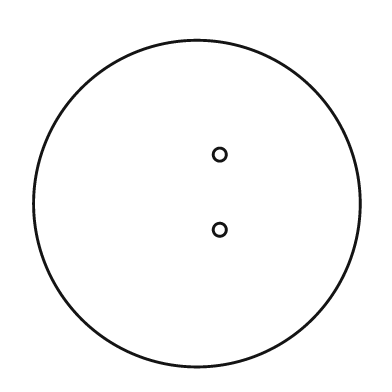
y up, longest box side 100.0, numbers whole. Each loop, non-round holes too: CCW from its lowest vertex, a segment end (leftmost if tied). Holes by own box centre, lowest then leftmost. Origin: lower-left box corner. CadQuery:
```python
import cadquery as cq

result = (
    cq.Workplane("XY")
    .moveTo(50.0, 50.0)
    .circle(50.0)
    .moveTo(57.0, 42.0)
    .circle(2.0)
    .moveTo(57.0, 65.0)
    .circle(2.0)
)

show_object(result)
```